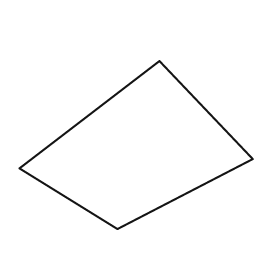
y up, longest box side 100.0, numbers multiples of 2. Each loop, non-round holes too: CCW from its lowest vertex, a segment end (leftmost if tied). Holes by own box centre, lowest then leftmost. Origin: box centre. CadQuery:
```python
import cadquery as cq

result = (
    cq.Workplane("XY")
    .moveTo(-8.0, -36.0)
    .lineTo(50.0, -6.0)
    .lineTo(10.0, 36.0)
    .lineTo(-50.0, -10.0)
    .close()
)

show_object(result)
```